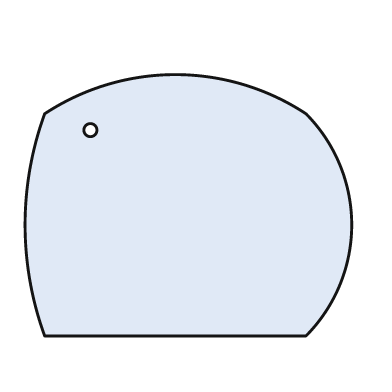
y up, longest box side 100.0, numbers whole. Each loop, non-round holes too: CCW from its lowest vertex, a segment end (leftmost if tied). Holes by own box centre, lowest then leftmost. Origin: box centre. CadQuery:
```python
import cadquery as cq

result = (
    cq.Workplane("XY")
    .moveTo(-44.0, -40.0)
    .lineTo(36.0, -40.0)
    .threePointArc((50.0, -6.0), (36.0, 28.0))
    .threePointArc((-4.0, 40.0), (-44.0, 28.0))
    .threePointArc((-50.0, -6.0), (-44.0, -40.0))
    .close()
    .moveTo(-30.0, 23.0)
    .circle(2.0)
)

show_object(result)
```